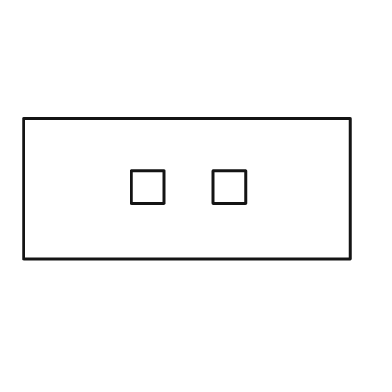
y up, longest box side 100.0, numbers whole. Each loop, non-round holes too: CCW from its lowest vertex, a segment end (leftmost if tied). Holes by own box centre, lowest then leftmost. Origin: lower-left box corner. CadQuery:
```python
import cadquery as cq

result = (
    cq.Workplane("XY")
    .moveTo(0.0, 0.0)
    .lineTo(100.0, 0.0)
    .lineTo(100.0, 43.0)
    .lineTo(0.0, 43.0)
    .close()
    .moveTo(33.0, 17.0)
    .lineTo(43.0, 17.0)
    .lineTo(43.0, 27.0)
    .lineTo(33.0, 27.0)
    .close()
    .moveTo(58.0, 17.0)
    .lineTo(68.0, 17.0)
    .lineTo(68.0, 27.0)
    .lineTo(58.0, 27.0)
    .close()
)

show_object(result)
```